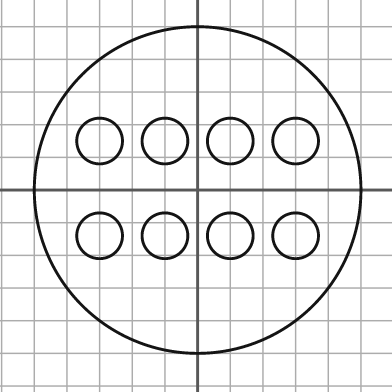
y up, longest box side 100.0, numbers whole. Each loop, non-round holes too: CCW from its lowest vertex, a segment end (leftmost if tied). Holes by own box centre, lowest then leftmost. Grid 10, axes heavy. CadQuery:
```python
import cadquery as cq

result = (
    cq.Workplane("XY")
    .moveTo(0.0, 0.0)
    .circle(50.0)
    .moveTo(-30.0, -14.0)
    .circle(7.0)
    .moveTo(-10.0, -14.0)
    .circle(7.0)
    .moveTo(10.0, -14.0)
    .circle(7.0)
    .moveTo(30.0, -14.0)
    .circle(7.0)
    .moveTo(-30.0, 15.0)
    .circle(7.0)
    .moveTo(-10.0, 15.0)
    .circle(7.0)
    .moveTo(10.0, 15.0)
    .circle(7.0)
    .moveTo(30.0, 15.0)
    .circle(7.0)
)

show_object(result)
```